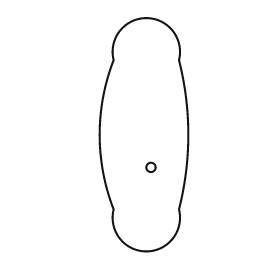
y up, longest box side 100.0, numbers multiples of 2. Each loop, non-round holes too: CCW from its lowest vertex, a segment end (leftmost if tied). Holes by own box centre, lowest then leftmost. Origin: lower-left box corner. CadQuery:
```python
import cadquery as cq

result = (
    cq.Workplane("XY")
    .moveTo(6.0, 18.0)
    .threePointArc((20.0, 0.0), (34.0, 18.0))
    .threePointArc((38.0, 50.0), (34.0, 82.0))
    .threePointArc((20.0, 100.0), (6.0, 82.0))
    .threePointArc((0.0, 50.0), (6.0, 18.0))
    .close()
    .moveTo(22.0, 36.0)
    .circle(2.0)
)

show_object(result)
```